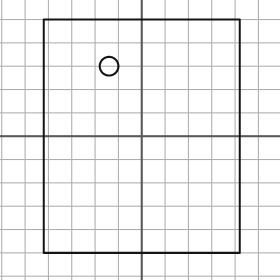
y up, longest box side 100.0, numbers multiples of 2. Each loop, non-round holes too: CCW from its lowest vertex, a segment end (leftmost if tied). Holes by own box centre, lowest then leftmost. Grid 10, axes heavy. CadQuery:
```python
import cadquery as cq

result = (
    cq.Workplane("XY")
    .moveTo(-42.0, -50.0)
    .lineTo(42.0, -50.0)
    .lineTo(42.0, 50.0)
    .lineTo(-42.0, 50.0)
    .close()
    .moveTo(-14.0, 30.0)
    .circle(4.0)
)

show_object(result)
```